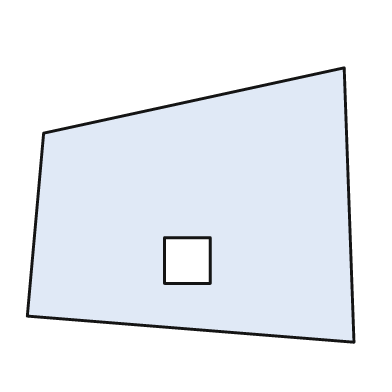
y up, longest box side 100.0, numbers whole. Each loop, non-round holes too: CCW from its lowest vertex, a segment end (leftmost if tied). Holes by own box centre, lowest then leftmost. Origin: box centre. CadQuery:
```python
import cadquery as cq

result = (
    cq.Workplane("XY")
    .moveTo(50.0, -42.0)
    .lineTo(47.0, 42.0)
    .lineTo(-45.0, 22.0)
    .lineTo(-50.0, -34.0)
    .close()
    .moveTo(-8.0, -24.0)
    .lineTo(6.0, -24.0)
    .lineTo(6.0, -10.0)
    .lineTo(-8.0, -10.0)
    .close()
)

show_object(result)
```